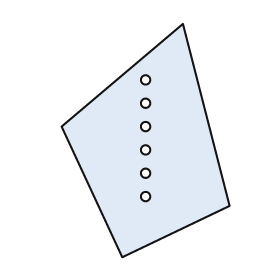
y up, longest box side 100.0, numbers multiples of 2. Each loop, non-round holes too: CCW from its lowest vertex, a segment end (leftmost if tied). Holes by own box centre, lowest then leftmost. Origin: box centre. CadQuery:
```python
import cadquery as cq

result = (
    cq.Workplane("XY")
    .moveTo(-10.0, -50.0)
    .lineTo(36.0, -28.0)
    .lineTo(16.0, 50.0)
    .lineTo(-36.0, 6.0)
    .close()
    .moveTo(0.0, -24.0)
    .circle(2.0)
    .moveTo(0.0, -14.0)
    .circle(2.0)
    .moveTo(0.0, -4.0)
    .circle(2.0)
    .moveTo(0.0, 6.0)
    .circle(2.0)
    .moveTo(0.0, 16.0)
    .circle(2.0)
    .moveTo(0.0, 26.0)
    .circle(2.0)
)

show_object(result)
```